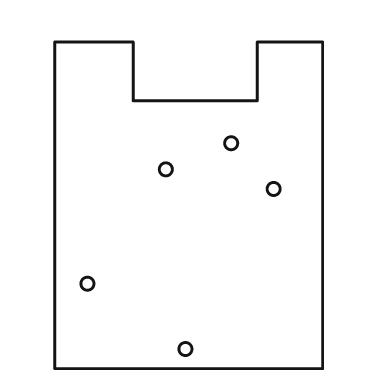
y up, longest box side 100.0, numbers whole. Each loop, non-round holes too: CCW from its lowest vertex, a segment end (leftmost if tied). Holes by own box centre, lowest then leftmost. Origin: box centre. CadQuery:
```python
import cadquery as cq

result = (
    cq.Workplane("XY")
    .moveTo(-41.0, -50.0)
    .lineTo(41.0, -50.0)
    .lineTo(41.0, 50.0)
    .lineTo(21.0, 50.0)
    .lineTo(21.0, 32.0)
    .lineTo(-17.0, 32.0)
    .lineTo(-17.0, 50.0)
    .lineTo(-41.0, 50.0)
    .close()
    .moveTo(-1.0, -44.0)
    .circle(2.0)
    .moveTo(-31.0, -24.0)
    .circle(2.0)
    .moveTo(26.0, 5.0)
    .circle(2.0)
    .moveTo(-7.0, 11.0)
    .circle(2.0)
    .moveTo(13.0, 19.0)
    .circle(2.0)
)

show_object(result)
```